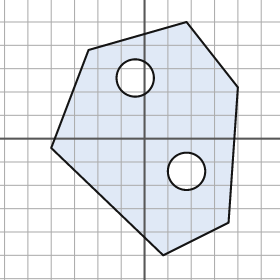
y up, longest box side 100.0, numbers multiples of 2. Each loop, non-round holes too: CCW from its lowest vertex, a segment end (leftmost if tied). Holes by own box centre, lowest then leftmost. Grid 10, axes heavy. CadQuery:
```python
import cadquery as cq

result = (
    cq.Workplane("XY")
    .moveTo(8.0, -50.0)
    .lineTo(36.0, -36.0)
    .lineTo(40.0, 22.0)
    .lineTo(18.0, 50.0)
    .lineTo(-24.0, 38.0)
    .lineTo(-40.0, -4.0)
    .close()
    .moveTo(18.0, -14.0)
    .circle(8.0)
    .moveTo(-4.0, 26.0)
    .circle(8.0)
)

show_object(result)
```